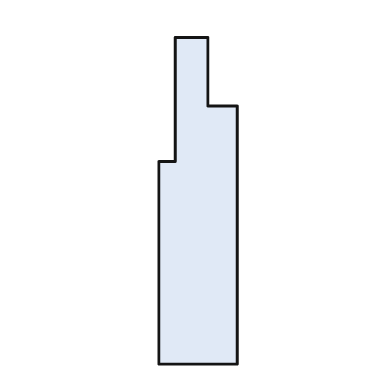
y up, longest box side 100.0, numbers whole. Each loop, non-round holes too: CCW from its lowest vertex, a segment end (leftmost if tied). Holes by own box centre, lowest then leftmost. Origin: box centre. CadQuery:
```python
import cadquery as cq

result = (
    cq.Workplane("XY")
    .moveTo(-12.0, -50.0)
    .lineTo(12.0, -50.0)
    .lineTo(12.0, 29.0)
    .lineTo(3.0, 29.0)
    .lineTo(3.0, 50.0)
    .lineTo(-7.0, 50.0)
    .lineTo(-7.0, 12.0)
    .lineTo(-12.0, 12.0)
    .close()
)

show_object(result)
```